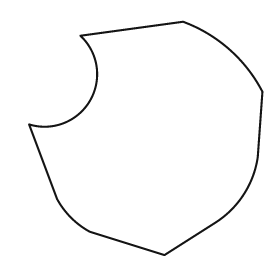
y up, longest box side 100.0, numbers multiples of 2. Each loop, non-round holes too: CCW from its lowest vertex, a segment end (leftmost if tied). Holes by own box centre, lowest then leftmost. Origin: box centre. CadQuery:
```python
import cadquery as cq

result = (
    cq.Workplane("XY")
    .moveTo(8.0, -50.0)
    .lineTo(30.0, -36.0)
    .threePointArc((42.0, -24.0), (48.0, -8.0))
    .lineTo(50.0, 20.0)
    .threePointArc((36.0, 38.0), (16.0, 50.0))
    .lineTo(-28.0, 44.0)
    .threePointArc((-24.0, 16.0), (-50.0, 6.0))
    .lineTo(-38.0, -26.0)
    .threePointArc((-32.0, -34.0), (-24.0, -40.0))
    .close()
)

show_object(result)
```